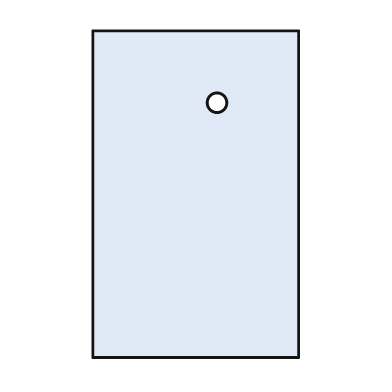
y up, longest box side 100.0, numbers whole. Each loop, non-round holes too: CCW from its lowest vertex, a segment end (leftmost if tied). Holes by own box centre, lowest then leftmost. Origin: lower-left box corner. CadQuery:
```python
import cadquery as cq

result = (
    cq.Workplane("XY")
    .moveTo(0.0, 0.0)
    .lineTo(63.0, 0.0)
    .lineTo(63.0, 100.0)
    .lineTo(0.0, 100.0)
    .close()
    .moveTo(38.0, 78.0)
    .circle(3.0)
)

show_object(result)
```